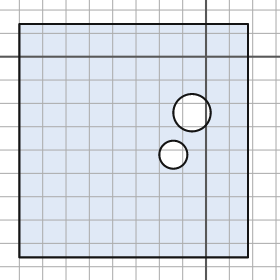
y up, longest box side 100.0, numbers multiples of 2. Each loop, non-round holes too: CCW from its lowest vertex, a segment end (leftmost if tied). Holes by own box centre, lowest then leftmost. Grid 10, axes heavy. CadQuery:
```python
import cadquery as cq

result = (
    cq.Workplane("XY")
    .moveTo(-80.0, -86.0)
    .lineTo(18.0, -86.0)
    .lineTo(18.0, 14.0)
    .lineTo(-80.0, 14.0)
    .close()
    .moveTo(-14.0, -42.0)
    .circle(6.0)
    .moveTo(-6.0, -24.0)
    .circle(8.0)
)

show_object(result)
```